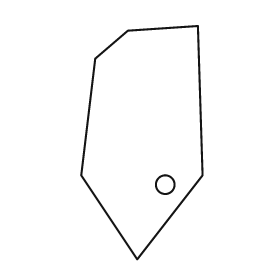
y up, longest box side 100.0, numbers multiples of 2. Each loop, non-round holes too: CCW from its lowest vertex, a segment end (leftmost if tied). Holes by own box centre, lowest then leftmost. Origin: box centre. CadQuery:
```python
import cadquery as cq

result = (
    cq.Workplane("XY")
    .moveTo(-2.0, -50.0)
    .lineTo(26.0, -14.0)
    .lineTo(24.0, 50.0)
    .lineTo(-6.0, 48.0)
    .lineTo(-20.0, 36.0)
    .lineTo(-26.0, -14.0)
    .close()
    .moveTo(10.0, -18.0)
    .circle(4.0)
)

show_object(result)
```